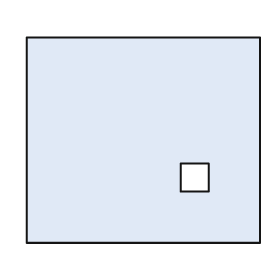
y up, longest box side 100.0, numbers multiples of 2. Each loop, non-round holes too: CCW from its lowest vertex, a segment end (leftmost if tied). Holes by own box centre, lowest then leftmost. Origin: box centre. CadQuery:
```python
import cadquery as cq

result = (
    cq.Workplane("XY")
    .moveTo(-50.0, -44.0)
    .lineTo(50.0, -44.0)
    .lineTo(50.0, 44.0)
    .lineTo(-50.0, 44.0)
    .close()
    .moveTo(16.0, -22.0)
    .lineTo(28.0, -22.0)
    .lineTo(28.0, -10.0)
    .lineTo(16.0, -10.0)
    .close()
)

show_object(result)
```